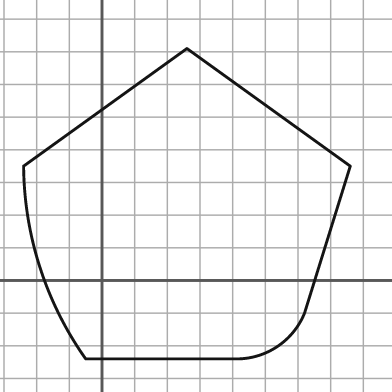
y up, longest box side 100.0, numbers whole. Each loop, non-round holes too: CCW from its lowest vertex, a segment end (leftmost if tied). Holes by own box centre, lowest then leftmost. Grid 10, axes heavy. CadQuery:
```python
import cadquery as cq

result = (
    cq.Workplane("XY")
    .moveTo(-5.0, -24.0)
    .lineTo(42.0, -24.0)
    .threePointArc((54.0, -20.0), (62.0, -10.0))
    .lineTo(76.0, 35.0)
    .lineTo(26.0, 71.0)
    .lineTo(-24.0, 35.0)
    .threePointArc((-19.0, 4.0), (-5.0, -24.0))
    .close()
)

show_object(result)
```